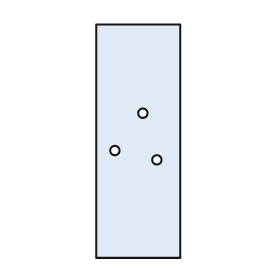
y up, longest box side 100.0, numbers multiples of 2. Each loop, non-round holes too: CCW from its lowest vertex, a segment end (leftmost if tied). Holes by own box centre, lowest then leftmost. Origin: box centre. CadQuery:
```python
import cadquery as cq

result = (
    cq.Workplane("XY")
    .moveTo(-18.0, -50.0)
    .lineTo(18.0, -50.0)
    .lineTo(18.0, 50.0)
    .lineTo(-18.0, 50.0)
    .close()
    .moveTo(8.0, -8.0)
    .circle(2.0)
    .moveTo(-10.0, -4.0)
    .circle(2.0)
    .moveTo(2.0, 12.0)
    .circle(2.0)
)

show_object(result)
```